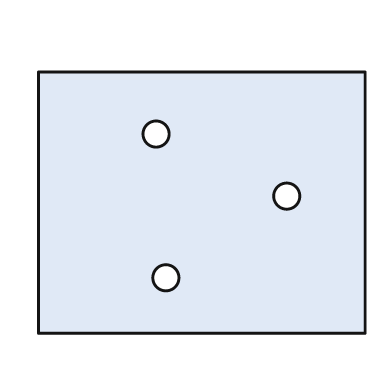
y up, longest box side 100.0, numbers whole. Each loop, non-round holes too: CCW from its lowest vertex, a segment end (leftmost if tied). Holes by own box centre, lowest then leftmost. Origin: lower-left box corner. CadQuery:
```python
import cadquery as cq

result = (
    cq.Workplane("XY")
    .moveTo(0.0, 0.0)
    .lineTo(100.0, 0.0)
    .lineTo(100.0, 80.0)
    .lineTo(0.0, 80.0)
    .close()
    .moveTo(39.0, 17.0)
    .circle(4.0)
    .moveTo(76.0, 42.0)
    .circle(4.0)
    .moveTo(36.0, 61.0)
    .circle(4.0)
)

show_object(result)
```